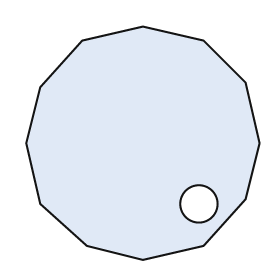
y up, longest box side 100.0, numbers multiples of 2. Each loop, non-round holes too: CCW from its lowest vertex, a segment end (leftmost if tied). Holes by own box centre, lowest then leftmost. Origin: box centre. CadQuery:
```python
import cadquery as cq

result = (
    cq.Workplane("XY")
    .moveTo(0.0, -50.0)
    .lineTo(26.0, -44.0)
    .lineTo(44.0, -24.0)
    .lineTo(50.0, 0.0)
    .lineTo(44.0, 26.0)
    .lineTo(26.0, 44.0)
    .lineTo(0.0, 50.0)
    .lineTo(-26.0, 44.0)
    .lineTo(-44.0, 24.0)
    .lineTo(-50.0, 0.0)
    .lineTo(-44.0, -26.0)
    .lineTo(-24.0, -44.0)
    .close()
    .moveTo(24.0, -26.0)
    .circle(8.0)
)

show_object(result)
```